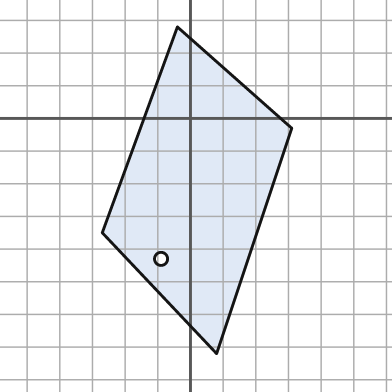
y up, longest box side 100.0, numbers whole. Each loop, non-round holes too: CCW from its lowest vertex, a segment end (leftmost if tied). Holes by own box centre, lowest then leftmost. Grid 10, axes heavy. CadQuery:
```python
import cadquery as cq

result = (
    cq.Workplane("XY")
    .moveTo(8.0, -72.0)
    .lineTo(31.0, -3.0)
    .lineTo(-4.0, 28.0)
    .lineTo(-27.0, -35.0)
    .close()
    .moveTo(-9.0, -43.0)
    .circle(2.0)
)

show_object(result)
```